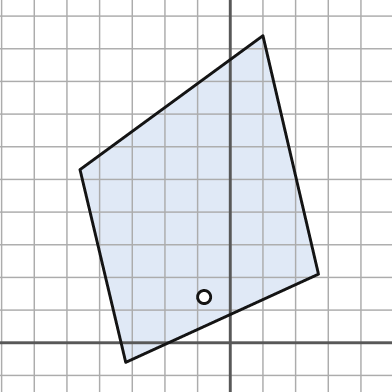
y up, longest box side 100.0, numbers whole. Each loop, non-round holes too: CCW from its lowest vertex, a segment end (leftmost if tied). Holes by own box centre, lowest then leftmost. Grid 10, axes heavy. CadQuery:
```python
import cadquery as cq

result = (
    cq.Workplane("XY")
    .moveTo(-32.0, -6.0)
    .lineTo(27.0, 21.0)
    .lineTo(10.0, 94.0)
    .lineTo(-46.0, 53.0)
    .close()
    .moveTo(-8.0, 14.0)
    .circle(2.0)
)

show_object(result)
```